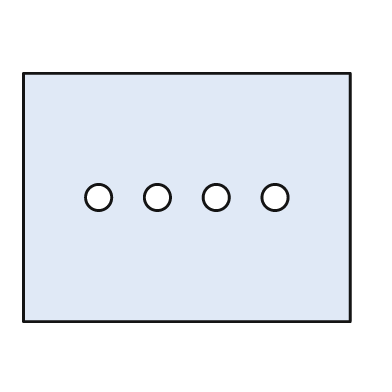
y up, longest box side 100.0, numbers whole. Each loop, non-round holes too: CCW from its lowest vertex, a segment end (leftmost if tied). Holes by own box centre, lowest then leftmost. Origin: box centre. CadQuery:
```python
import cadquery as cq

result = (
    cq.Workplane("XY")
    .moveTo(-50.0, -38.0)
    .lineTo(50.0, -38.0)
    .lineTo(50.0, 38.0)
    .lineTo(-50.0, 38.0)
    .close()
    .moveTo(-27.0, 0.0)
    .circle(4.0)
    .moveTo(-9.0, 0.0)
    .circle(4.0)
    .moveTo(9.0, 0.0)
    .circle(4.0)
    .moveTo(27.0, 0.0)
    .circle(4.0)
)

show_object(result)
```